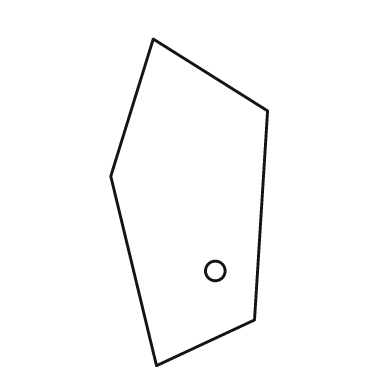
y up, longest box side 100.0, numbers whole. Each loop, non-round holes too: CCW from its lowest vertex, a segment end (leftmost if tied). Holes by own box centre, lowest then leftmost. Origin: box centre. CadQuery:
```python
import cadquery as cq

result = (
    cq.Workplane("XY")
    .moveTo(-10.0, -50.0)
    .lineTo(20.0, -36.0)
    .lineTo(24.0, 28.0)
    .lineTo(-11.0, 50.0)
    .lineTo(-24.0, 8.0)
    .close()
    .moveTo(8.0, -21.0)
    .circle(3.0)
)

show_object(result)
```